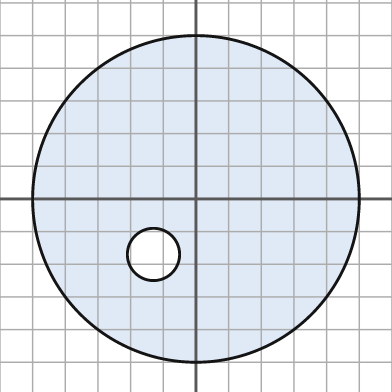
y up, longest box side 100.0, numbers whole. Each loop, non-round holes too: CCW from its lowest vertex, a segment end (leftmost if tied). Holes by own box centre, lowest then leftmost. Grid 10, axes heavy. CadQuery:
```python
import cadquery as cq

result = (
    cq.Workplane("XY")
    .moveTo(0.0, 0.0)
    .circle(50.0)
    .moveTo(-13.0, -17.0)
    .circle(8.0)
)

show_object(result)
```